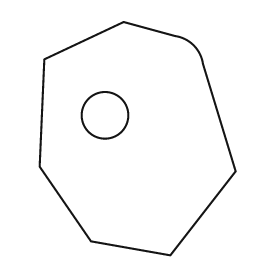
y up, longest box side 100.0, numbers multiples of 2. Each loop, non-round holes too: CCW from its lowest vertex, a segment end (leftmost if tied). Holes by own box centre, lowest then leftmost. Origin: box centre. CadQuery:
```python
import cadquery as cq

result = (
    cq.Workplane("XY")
    .moveTo(14.0, -50.0)
    .lineTo(42.0, -14.0)
    .lineTo(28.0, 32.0)
    .threePointArc((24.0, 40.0), (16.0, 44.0))
    .lineTo(-6.0, 50.0)
    .lineTo(-40.0, 34.0)
    .lineTo(-42.0, -12.0)
    .lineTo(-20.0, -44.0)
    .close()
    .moveTo(-14.0, 10.0)
    .circle(10.0)
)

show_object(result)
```